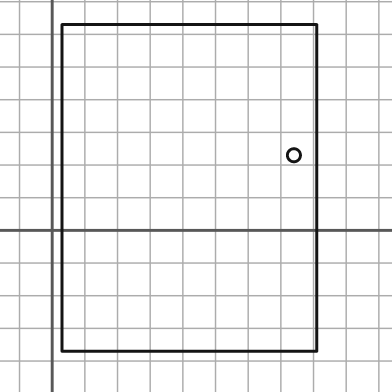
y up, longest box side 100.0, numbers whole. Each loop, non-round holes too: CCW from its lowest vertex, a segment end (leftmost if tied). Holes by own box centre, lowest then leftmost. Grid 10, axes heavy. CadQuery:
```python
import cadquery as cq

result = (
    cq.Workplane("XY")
    .moveTo(3.0, -37.0)
    .lineTo(81.0, -37.0)
    .lineTo(81.0, 63.0)
    .lineTo(3.0, 63.0)
    .close()
    .moveTo(74.0, 23.0)
    .circle(2.0)
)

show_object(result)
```